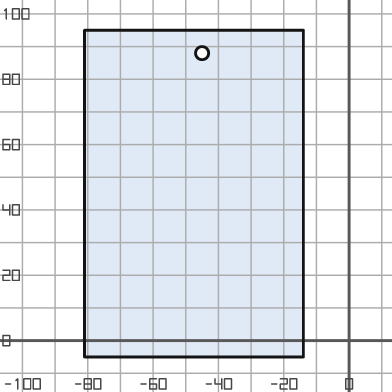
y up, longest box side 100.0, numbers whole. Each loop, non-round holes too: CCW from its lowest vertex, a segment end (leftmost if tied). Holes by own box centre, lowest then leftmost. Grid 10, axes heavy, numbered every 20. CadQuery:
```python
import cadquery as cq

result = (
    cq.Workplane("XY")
    .moveTo(-81.0, -5.0)
    .lineTo(-14.0, -5.0)
    .lineTo(-14.0, 95.0)
    .lineTo(-81.0, 95.0)
    .close()
    .moveTo(-45.0, 88.0)
    .circle(2.0)
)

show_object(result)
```